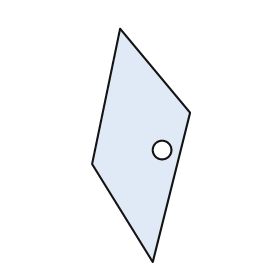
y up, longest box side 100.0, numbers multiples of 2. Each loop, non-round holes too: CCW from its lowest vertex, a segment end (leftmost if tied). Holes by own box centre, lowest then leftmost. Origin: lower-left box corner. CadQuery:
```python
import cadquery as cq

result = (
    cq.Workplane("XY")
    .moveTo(26.0, 0.0)
    .lineTo(42.0, 64.0)
    .lineTo(12.0, 100.0)
    .lineTo(0.0, 42.0)
    .close()
    .moveTo(30.0, 48.0)
    .circle(4.0)
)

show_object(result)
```